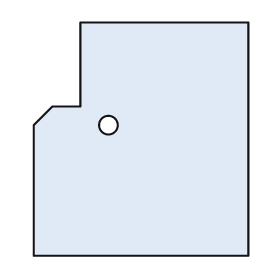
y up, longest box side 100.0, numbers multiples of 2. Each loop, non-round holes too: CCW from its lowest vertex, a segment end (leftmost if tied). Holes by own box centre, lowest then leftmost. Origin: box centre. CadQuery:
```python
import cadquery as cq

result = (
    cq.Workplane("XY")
    .moveTo(-46.0, -50.0)
    .lineTo(46.0, -50.0)
    .lineTo(46.0, 50.0)
    .lineTo(-26.0, 50.0)
    .lineTo(-26.0, 14.0)
    .lineTo(-38.0, 14.0)
    .lineTo(-46.0, 6.0)
    .close()
    .moveTo(-14.0, 6.0)
    .circle(4.0)
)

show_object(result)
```